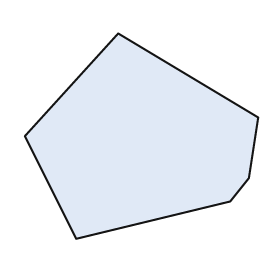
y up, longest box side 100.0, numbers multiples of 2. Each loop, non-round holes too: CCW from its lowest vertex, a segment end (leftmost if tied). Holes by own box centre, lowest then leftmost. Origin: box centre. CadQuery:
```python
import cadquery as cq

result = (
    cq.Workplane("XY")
    .moveTo(-28.0, -44.0)
    .lineTo(38.0, -28.0)
    .lineTo(46.0, -18.0)
    .lineTo(50.0, 8.0)
    .lineTo(-10.0, 44.0)
    .lineTo(-50.0, 0.0)
    .close()
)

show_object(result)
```